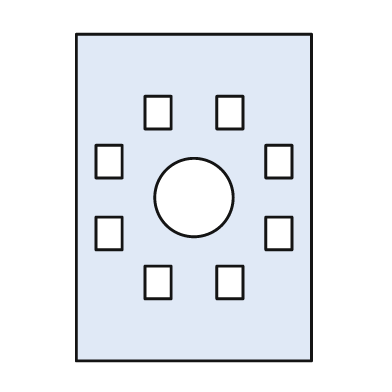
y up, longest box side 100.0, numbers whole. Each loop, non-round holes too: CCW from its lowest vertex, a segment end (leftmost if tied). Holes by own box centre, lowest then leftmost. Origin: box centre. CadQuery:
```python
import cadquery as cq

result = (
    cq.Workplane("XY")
    .moveTo(-36.0, -50.0)
    .lineTo(36.0, -50.0)
    .lineTo(36.0, 50.0)
    .lineTo(-36.0, 50.0)
    .close()
    .moveTo(-15.0, -31.0)
    .lineTo(-7.0, -31.0)
    .lineTo(-7.0, -21.0)
    .lineTo(-15.0, -21.0)
    .close()
    .moveTo(7.0, -31.0)
    .lineTo(15.0, -31.0)
    .lineTo(15.0, -21.0)
    .lineTo(7.0, -21.0)
    .close()
    .moveTo(-30.0, -16.0)
    .lineTo(-22.0, -16.0)
    .lineTo(-22.0, -6.0)
    .lineTo(-30.0, -6.0)
    .close()
    .moveTo(22.0, -16.0)
    .lineTo(30.0, -16.0)
    .lineTo(30.0, -6.0)
    .lineTo(22.0, -6.0)
    .close()
    .moveTo(0.0, 0.0)
    .circle(12.0)
    .moveTo(-30.0, 6.0)
    .lineTo(-22.0, 6.0)
    .lineTo(-22.0, 16.0)
    .lineTo(-30.0, 16.0)
    .close()
    .moveTo(22.0, 6.0)
    .lineTo(30.0, 6.0)
    .lineTo(30.0, 16.0)
    .lineTo(22.0, 16.0)
    .close()
    .moveTo(-15.0, 21.0)
    .lineTo(-7.0, 21.0)
    .lineTo(-7.0, 31.0)
    .lineTo(-15.0, 31.0)
    .close()
    .moveTo(7.0, 21.0)
    .lineTo(15.0, 21.0)
    .lineTo(15.0, 31.0)
    .lineTo(7.0, 31.0)
    .close()
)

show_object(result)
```